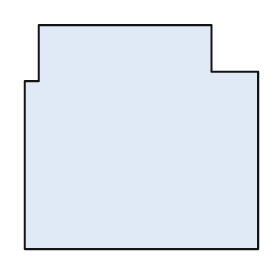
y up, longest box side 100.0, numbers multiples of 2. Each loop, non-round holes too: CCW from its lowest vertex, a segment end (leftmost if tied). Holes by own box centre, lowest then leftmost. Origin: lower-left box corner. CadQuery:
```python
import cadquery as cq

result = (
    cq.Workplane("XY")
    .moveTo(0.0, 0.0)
    .lineTo(100.0, 0.0)
    .lineTo(100.0, 76.0)
    .lineTo(80.0, 76.0)
    .lineTo(80.0, 96.0)
    .lineTo(6.0, 96.0)
    .lineTo(6.0, 72.0)
    .lineTo(0.0, 72.0)
    .close()
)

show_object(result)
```